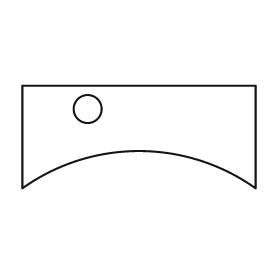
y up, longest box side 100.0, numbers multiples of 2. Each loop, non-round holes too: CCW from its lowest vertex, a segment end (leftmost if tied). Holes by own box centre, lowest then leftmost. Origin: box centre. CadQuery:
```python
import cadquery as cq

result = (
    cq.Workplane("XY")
    .moveTo(-50.0, -22.0)
    .threePointArc((0.0, -6.0), (50.0, -22.0))
    .lineTo(50.0, 22.0)
    .lineTo(-50.0, 22.0)
    .close()
    .moveTo(-22.0, 12.0)
    .circle(6.0)
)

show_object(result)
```